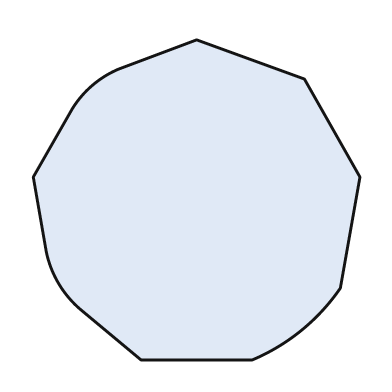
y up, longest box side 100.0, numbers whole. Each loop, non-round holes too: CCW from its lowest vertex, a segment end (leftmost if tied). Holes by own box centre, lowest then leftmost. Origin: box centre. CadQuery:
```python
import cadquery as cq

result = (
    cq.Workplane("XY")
    .moveTo(-17.0, -49.0)
    .lineTo(17.0, -49.0)
    .threePointArc((32.0, -40.0), (44.0, -27.0))
    .lineTo(50.0, 7.0)
    .lineTo(33.0, 37.0)
    .lineTo(0.0, 49.0)
    .lineTo(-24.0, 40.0)
    .threePointArc((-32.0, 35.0), (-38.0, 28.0))
    .lineTo(-50.0, 7.0)
    .lineTo(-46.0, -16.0)
    .threePointArc((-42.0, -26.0), (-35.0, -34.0))
    .close()
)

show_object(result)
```